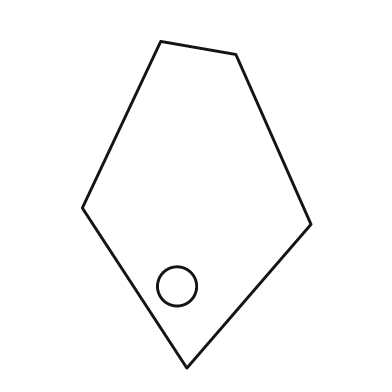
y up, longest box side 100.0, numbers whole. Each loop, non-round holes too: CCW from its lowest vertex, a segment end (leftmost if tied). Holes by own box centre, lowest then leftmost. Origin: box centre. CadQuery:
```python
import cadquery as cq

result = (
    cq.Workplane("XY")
    .moveTo(-3.0, -50.0)
    .lineTo(35.0, -6.0)
    .lineTo(12.0, 46.0)
    .lineTo(-11.0, 50.0)
    .lineTo(-35.0, -1.0)
    .close()
    .moveTo(-6.0, -25.0)
    .circle(6.0)
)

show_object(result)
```